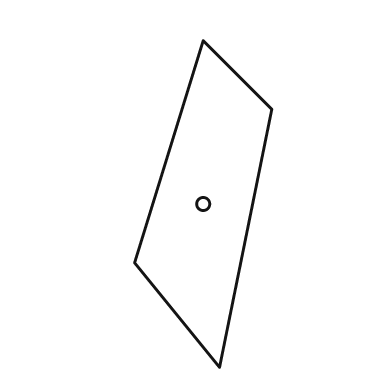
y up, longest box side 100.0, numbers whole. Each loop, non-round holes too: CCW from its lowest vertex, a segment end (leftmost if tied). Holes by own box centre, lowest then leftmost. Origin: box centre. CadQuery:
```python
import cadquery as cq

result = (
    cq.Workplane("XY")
    .moveTo(5.0, -50.0)
    .lineTo(21.0, 29.0)
    .lineTo(0.0, 50.0)
    .lineTo(-21.0, -18.0)
    .close()
    .moveTo(0.0, 0.0)
    .circle(2.0)
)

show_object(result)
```